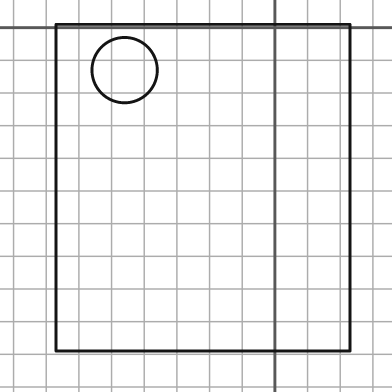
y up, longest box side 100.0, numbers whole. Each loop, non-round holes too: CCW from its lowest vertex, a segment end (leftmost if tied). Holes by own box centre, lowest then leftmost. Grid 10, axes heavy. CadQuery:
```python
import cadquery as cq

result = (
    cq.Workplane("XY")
    .moveTo(-67.0, -99.0)
    .lineTo(23.0, -99.0)
    .lineTo(23.0, 1.0)
    .lineTo(-67.0, 1.0)
    .close()
    .moveTo(-46.0, -13.0)
    .circle(10.0)
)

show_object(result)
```